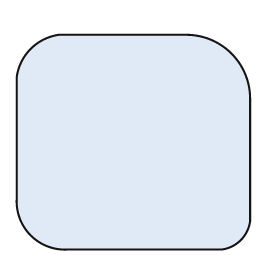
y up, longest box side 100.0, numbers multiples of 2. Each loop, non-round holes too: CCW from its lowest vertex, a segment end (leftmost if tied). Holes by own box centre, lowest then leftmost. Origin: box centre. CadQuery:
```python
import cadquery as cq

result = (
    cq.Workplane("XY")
    .moveTo(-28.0, -46.0)
    .lineTo(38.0, -46.0)
    .threePointArc((46.0, -42.0), (50.0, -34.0))
    .lineTo(50.0, 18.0)
    .threePointArc((42.0, 38.0), (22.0, 46.0))
    .lineTo(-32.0, 46.0)
    .threePointArc((-44.0, 40.0), (-50.0, 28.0))
    .lineTo(-50.0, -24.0)
    .threePointArc((-44.0, -40.0), (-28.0, -46.0))
    .close()
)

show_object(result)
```